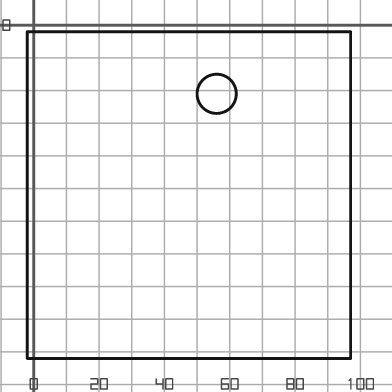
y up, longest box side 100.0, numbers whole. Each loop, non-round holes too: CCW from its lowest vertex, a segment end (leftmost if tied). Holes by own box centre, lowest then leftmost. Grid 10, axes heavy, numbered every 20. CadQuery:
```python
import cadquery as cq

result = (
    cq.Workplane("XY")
    .moveTo(-2.0, -102.0)
    .lineTo(97.0, -102.0)
    .lineTo(97.0, -2.0)
    .lineTo(-2.0, -2.0)
    .close()
    .moveTo(56.0, -21.0)
    .circle(6.0)
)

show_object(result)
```